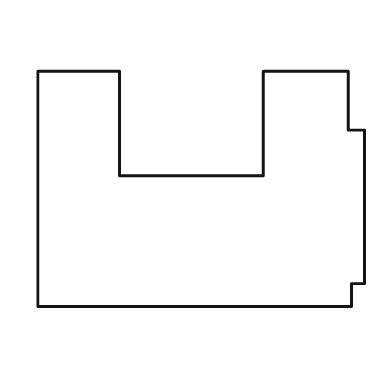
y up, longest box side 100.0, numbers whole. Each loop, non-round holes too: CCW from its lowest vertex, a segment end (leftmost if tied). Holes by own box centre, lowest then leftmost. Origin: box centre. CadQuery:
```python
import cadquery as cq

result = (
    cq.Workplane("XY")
    .moveTo(-50.0, -36.0)
    .lineTo(46.0, -36.0)
    .lineTo(46.0, -29.0)
    .lineTo(50.0, -29.0)
    .lineTo(50.0, 18.0)
    .lineTo(45.0, 18.0)
    .lineTo(45.0, 36.0)
    .lineTo(19.0, 36.0)
    .lineTo(19.0, 4.0)
    .lineTo(-25.0, 4.0)
    .lineTo(-25.0, 36.0)
    .lineTo(-50.0, 36.0)
    .close()
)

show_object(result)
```